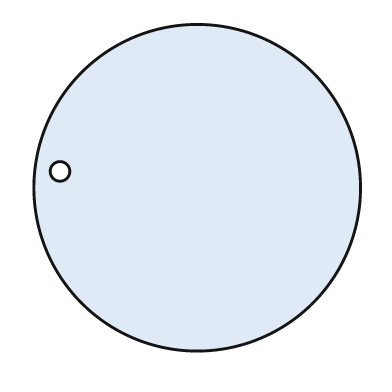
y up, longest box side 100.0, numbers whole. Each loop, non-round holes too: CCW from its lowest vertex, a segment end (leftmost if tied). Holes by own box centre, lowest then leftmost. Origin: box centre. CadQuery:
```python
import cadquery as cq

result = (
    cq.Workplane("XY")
    .moveTo(0.0, 0.0)
    .circle(50.0)
    .moveTo(-42.0, 5.0)
    .circle(3.0)
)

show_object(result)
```